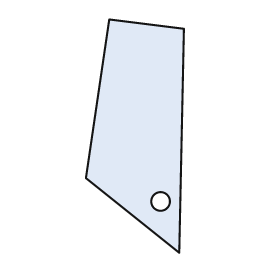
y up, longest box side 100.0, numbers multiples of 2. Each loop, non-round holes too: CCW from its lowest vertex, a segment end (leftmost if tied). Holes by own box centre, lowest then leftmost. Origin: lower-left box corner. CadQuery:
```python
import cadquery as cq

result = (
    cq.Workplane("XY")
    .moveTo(40.0, 0.0)
    .lineTo(42.0, 96.0)
    .lineTo(10.0, 100.0)
    .lineTo(0.0, 32.0)
    .close()
    .moveTo(32.0, 22.0)
    .circle(4.0)
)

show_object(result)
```